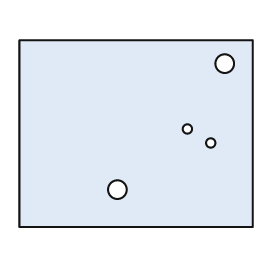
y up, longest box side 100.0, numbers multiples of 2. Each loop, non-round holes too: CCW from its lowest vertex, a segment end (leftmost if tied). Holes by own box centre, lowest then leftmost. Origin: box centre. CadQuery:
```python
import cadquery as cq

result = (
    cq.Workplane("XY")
    .moveTo(-50.0, -40.0)
    .lineTo(50.0, -40.0)
    .lineTo(50.0, 40.0)
    .lineTo(-50.0, 40.0)
    .close()
    .moveTo(-8.0, -24.0)
    .circle(4.0)
    .moveTo(32.0, -4.0)
    .circle(2.0)
    .moveTo(22.0, 2.0)
    .circle(2.0)
    .moveTo(38.0, 30.0)
    .circle(4.0)
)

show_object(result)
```